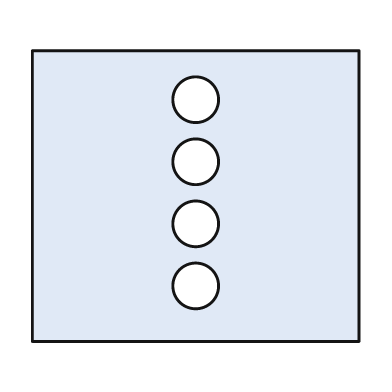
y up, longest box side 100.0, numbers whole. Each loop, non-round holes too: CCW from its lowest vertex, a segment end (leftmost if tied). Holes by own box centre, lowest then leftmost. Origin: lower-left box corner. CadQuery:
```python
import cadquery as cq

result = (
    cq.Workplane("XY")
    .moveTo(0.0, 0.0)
    .lineTo(100.0, 0.0)
    .lineTo(100.0, 89.0)
    .lineTo(0.0, 89.0)
    .close()
    .moveTo(50.0, 17.0)
    .circle(7.0)
    .moveTo(50.0, 36.0)
    .circle(7.0)
    .moveTo(50.0, 55.0)
    .circle(7.0)
    .moveTo(50.0, 74.0)
    .circle(7.0)
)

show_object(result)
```